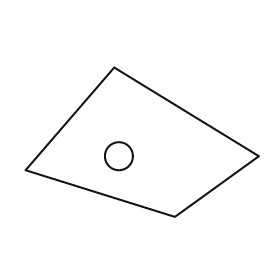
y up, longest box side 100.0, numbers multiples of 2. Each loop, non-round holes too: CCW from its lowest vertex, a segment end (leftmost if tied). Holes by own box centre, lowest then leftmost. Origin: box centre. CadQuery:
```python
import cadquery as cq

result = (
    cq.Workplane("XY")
    .moveTo(14.0, -32.0)
    .lineTo(50.0, -6.0)
    .lineTo(-12.0, 32.0)
    .lineTo(-50.0, -12.0)
    .close()
    .moveTo(-10.0, -6.0)
    .circle(6.0)
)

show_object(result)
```